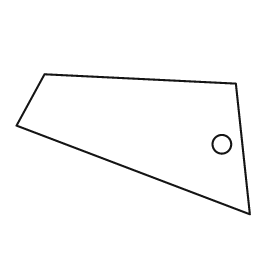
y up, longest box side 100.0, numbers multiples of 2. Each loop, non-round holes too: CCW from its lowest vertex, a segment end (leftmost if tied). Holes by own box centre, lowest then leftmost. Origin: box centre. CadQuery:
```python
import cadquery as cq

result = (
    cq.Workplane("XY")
    .moveTo(50.0, -30.0)
    .lineTo(44.0, 26.0)
    .lineTo(-38.0, 30.0)
    .lineTo(-50.0, 8.0)
    .close()
    .moveTo(38.0, 0.0)
    .circle(4.0)
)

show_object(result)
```